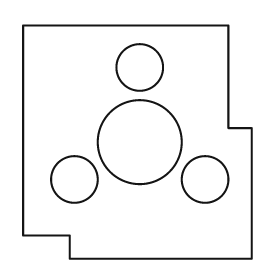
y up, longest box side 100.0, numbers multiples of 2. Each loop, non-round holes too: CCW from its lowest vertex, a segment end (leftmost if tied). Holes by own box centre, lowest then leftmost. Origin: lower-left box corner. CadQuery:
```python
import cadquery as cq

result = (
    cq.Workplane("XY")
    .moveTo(20.0, 0.0)
    .lineTo(98.0, 0.0)
    .lineTo(98.0, 56.0)
    .lineTo(88.0, 56.0)
    .lineTo(88.0, 100.0)
    .lineTo(0.0, 100.0)
    .lineTo(0.0, 10.0)
    .lineTo(20.0, 10.0)
    .close()
    .moveTo(22.0, 34.0)
    .circle(10.0)
    .moveTo(78.0, 34.0)
    .circle(10.0)
    .moveTo(50.0, 50.0)
    .circle(18.0)
    .moveTo(50.0, 82.0)
    .circle(10.0)
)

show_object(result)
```